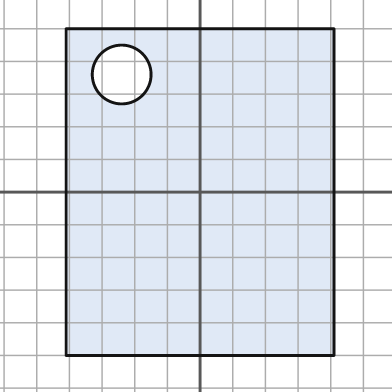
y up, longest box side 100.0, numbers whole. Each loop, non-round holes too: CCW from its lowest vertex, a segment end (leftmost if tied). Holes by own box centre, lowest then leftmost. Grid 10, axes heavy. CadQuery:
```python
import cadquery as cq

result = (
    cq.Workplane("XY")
    .moveTo(-41.0, -50.0)
    .lineTo(41.0, -50.0)
    .lineTo(41.0, 50.0)
    .lineTo(-41.0, 50.0)
    .close()
    .moveTo(-24.0, 36.0)
    .circle(9.0)
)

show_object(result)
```